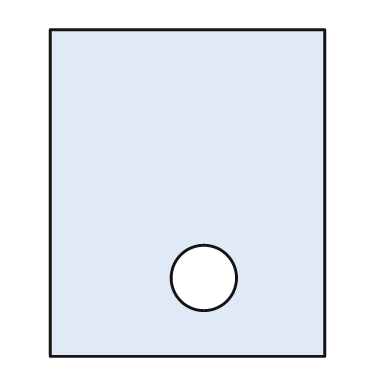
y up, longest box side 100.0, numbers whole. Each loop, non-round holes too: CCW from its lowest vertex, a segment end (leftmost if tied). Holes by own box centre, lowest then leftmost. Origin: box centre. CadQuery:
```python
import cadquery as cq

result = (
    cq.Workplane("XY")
    .moveTo(-42.0, -50.0)
    .lineTo(42.0, -50.0)
    .lineTo(42.0, 50.0)
    .lineTo(-42.0, 50.0)
    .close()
    .moveTo(5.0, -26.0)
    .circle(10.0)
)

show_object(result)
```